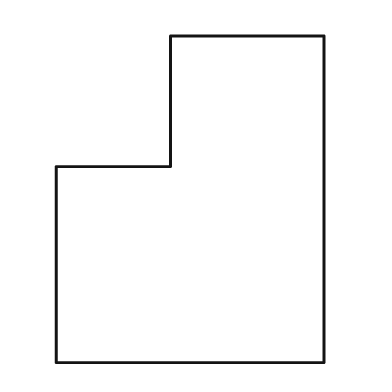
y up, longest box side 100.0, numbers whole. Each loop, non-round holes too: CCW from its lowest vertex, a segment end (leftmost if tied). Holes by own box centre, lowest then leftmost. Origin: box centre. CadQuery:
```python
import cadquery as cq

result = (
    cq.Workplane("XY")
    .moveTo(-41.0, -50.0)
    .lineTo(41.0, -50.0)
    .lineTo(41.0, 50.0)
    .lineTo(-6.0, 50.0)
    .lineTo(-6.0, 10.0)
    .lineTo(-41.0, 10.0)
    .close()
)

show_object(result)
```